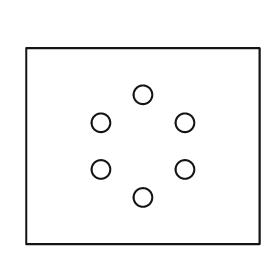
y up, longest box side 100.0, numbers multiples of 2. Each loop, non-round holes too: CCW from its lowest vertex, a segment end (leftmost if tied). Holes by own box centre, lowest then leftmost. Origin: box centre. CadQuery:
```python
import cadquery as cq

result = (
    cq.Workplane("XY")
    .moveTo(-50.0, -42.0)
    .lineTo(50.0, -42.0)
    .lineTo(50.0, 42.0)
    .lineTo(-50.0, 42.0)
    .close()
    .moveTo(0.0, -22.0)
    .circle(4.0)
    .moveTo(-18.0, -10.0)
    .circle(4.0)
    .moveTo(18.0, -10.0)
    .circle(4.0)
    .moveTo(-18.0, 10.0)
    .circle(4.0)
    .moveTo(18.0, 10.0)
    .circle(4.0)
    .moveTo(0.0, 22.0)
    .circle(4.0)
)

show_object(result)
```